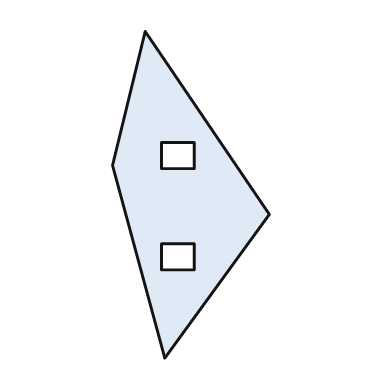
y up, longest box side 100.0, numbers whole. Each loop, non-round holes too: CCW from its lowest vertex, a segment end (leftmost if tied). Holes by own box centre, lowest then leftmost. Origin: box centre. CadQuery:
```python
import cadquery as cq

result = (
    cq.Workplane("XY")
    .moveTo(-8.0, -50.0)
    .lineTo(24.0, -6.0)
    .lineTo(-14.0, 50.0)
    .lineTo(-24.0, 9.0)
    .close()
    .moveTo(-9.0, -23.0)
    .lineTo(1.0, -23.0)
    .lineTo(1.0, -15.0)
    .lineTo(-9.0, -15.0)
    .close()
    .moveTo(-9.0, 8.0)
    .lineTo(1.0, 8.0)
    .lineTo(1.0, 16.0)
    .lineTo(-9.0, 16.0)
    .close()
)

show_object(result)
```